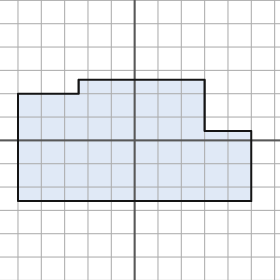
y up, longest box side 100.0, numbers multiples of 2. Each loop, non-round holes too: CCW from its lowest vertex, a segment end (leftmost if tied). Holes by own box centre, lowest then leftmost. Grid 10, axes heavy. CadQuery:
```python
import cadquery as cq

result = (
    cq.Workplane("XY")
    .moveTo(-50.0, -26.0)
    .lineTo(50.0, -26.0)
    .lineTo(50.0, 4.0)
    .lineTo(30.0, 4.0)
    .lineTo(30.0, 26.0)
    .lineTo(-24.0, 26.0)
    .lineTo(-24.0, 20.0)
    .lineTo(-50.0, 20.0)
    .close()
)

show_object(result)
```